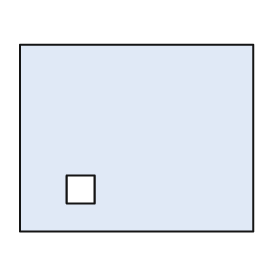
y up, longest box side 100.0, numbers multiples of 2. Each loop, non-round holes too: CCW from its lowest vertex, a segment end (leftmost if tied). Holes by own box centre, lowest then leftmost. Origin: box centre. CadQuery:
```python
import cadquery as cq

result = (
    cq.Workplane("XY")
    .moveTo(-50.0, -40.0)
    .lineTo(50.0, -40.0)
    .lineTo(50.0, 40.0)
    .lineTo(-50.0, 40.0)
    .close()
    .moveTo(-30.0, -28.0)
    .lineTo(-18.0, -28.0)
    .lineTo(-18.0, -16.0)
    .lineTo(-30.0, -16.0)
    .close()
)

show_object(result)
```